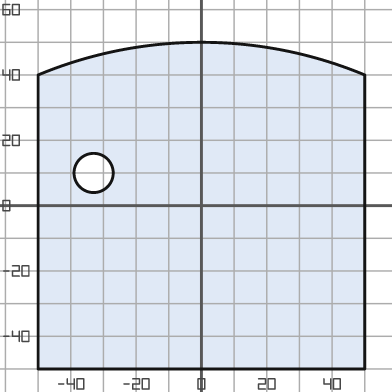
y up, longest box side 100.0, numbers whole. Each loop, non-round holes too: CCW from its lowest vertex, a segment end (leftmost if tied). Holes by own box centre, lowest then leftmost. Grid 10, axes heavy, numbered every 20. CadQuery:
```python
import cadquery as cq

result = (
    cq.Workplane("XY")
    .moveTo(-50.0, -50.0)
    .lineTo(50.0, -50.0)
    .lineTo(50.0, 40.0)
    .threePointArc((0.0, 50.0), (-50.0, 40.0))
    .close()
    .moveTo(-33.0, 10.0)
    .circle(6.0)
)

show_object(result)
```